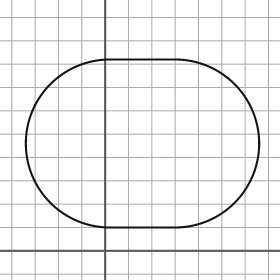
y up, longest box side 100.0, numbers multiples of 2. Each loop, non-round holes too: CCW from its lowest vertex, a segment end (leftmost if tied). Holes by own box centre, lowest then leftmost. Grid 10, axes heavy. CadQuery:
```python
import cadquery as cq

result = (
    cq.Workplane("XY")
    .moveTo(2.0, 10.0)
    .lineTo(30.0, 10.0)
    .threePointArc((66.0, 46.0), (30.0, 82.0))
    .lineTo(2.0, 82.0)
    .threePointArc((-34.0, 46.0), (2.0, 10.0))
    .close()
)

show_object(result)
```